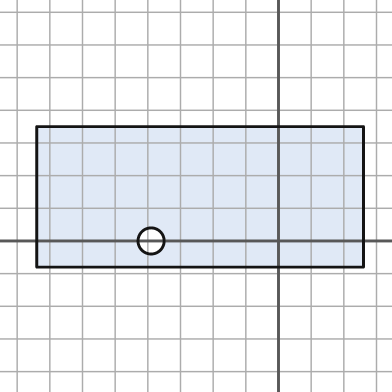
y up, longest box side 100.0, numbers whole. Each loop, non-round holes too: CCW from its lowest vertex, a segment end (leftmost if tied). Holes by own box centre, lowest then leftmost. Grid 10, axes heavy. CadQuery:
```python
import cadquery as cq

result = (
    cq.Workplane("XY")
    .moveTo(-74.0, -8.0)
    .lineTo(26.0, -8.0)
    .lineTo(26.0, 35.0)
    .lineTo(-74.0, 35.0)
    .close()
    .moveTo(-39.0, 0.0)
    .circle(4.0)
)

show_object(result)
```